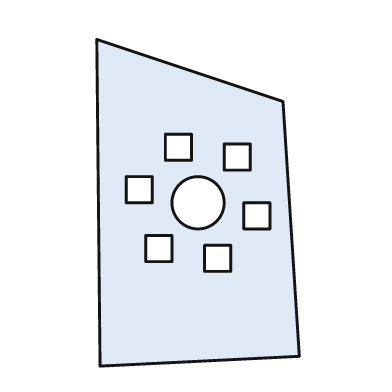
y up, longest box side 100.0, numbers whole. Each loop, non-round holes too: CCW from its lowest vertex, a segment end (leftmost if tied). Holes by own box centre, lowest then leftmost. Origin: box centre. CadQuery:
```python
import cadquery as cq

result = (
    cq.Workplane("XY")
    .moveTo(-30.0, -50.0)
    .lineTo(31.0, -47.0)
    .lineTo(26.0, 31.0)
    .lineTo(-31.0, 50.0)
    .close()
    .moveTo(2.0, -21.0)
    .lineTo(10.0, -21.0)
    .lineTo(10.0, -13.0)
    .lineTo(2.0, -13.0)
    .close()
    .moveTo(-16.0, -18.0)
    .lineTo(-8.0, -18.0)
    .lineTo(-8.0, -10.0)
    .lineTo(-16.0, -10.0)
    .close()
    .moveTo(14.0, -8.0)
    .lineTo(22.0, -8.0)
    .lineTo(22.0, 0.0)
    .lineTo(14.0, 0.0)
    .close()
    .moveTo(0.0, 0.0)
    .circle(8.0)
    .moveTo(-22.0, 0.0)
    .lineTo(-14.0, 0.0)
    .lineTo(-14.0, 8.0)
    .lineTo(-22.0, 8.0)
    .close()
    .moveTo(8.0, 10.0)
    .lineTo(16.0, 10.0)
    .lineTo(16.0, 18.0)
    .lineTo(8.0, 18.0)
    .close()
    .moveTo(-10.0, 13.0)
    .lineTo(-2.0, 13.0)
    .lineTo(-2.0, 21.0)
    .lineTo(-10.0, 21.0)
    .close()
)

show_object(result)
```